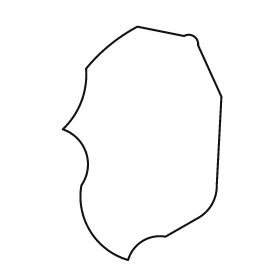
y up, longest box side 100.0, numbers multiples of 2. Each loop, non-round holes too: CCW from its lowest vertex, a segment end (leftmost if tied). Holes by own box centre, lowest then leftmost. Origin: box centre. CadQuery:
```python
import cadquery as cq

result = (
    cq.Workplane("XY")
    .moveTo(-6.0, -50.0)
    .threePointArc((0.0, -42.0), (10.0, -40.0))
    .lineTo(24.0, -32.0)
    .threePointArc((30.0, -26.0), (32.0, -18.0))
    .lineTo(34.0, 20.0)
    .lineTo(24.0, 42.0)
    .threePointArc((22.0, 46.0), (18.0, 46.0))
    .lineTo(-2.0, 50.0)
    .threePointArc((-14.0, 42.0), (-24.0, 32.0))
    .threePointArc((-26.0, 18.0), (-34.0, 6.0))
    .threePointArc((-24.0, -4.0), (-26.0, -18.0))
    .threePointArc((-22.0, -38.0), (-6.0, -50.0))
    .close()
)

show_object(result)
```